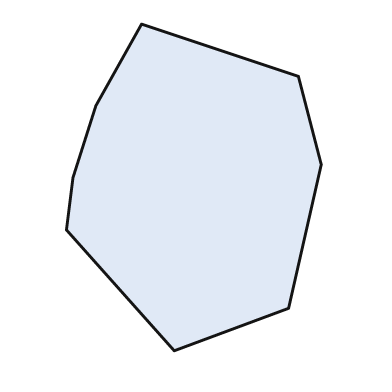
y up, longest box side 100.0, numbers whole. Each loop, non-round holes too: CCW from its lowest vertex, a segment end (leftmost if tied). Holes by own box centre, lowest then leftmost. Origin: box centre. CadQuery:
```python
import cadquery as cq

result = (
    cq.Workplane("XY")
    .moveTo(-6.0, -50.0)
    .lineTo(29.0, -37.0)
    .lineTo(39.0, 7.0)
    .lineTo(32.0, 34.0)
    .lineTo(-16.0, 50.0)
    .lineTo(-30.0, 25.0)
    .lineTo(-37.0, 3.0)
    .lineTo(-39.0, -13.0)
    .close()
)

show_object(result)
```